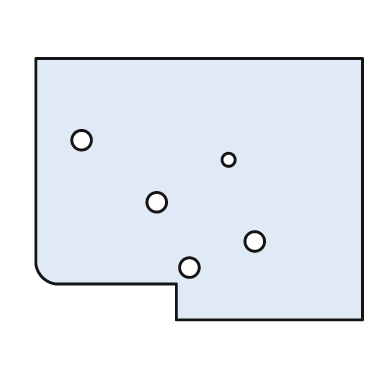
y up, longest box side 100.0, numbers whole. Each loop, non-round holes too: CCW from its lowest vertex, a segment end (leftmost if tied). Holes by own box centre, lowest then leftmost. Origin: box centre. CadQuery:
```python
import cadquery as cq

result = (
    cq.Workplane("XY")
    .moveTo(-7.0, -40.0)
    .lineTo(50.0, -40.0)
    .lineTo(50.0, 40.0)
    .lineTo(-50.0, 40.0)
    .lineTo(-50.0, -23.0)
    .threePointArc((-48.0, -27.0), (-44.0, -29.0))
    .lineTo(-7.0, -29.0)
    .close()
    .moveTo(-3.0, -24.0)
    .circle(3.0)
    .moveTo(17.0, -16.0)
    .circle(3.0)
    .moveTo(-13.0, -4.0)
    .circle(3.0)
    .moveTo(9.0, 9.0)
    .circle(2.0)
    .moveTo(-36.0, 15.0)
    .circle(3.0)
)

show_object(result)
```